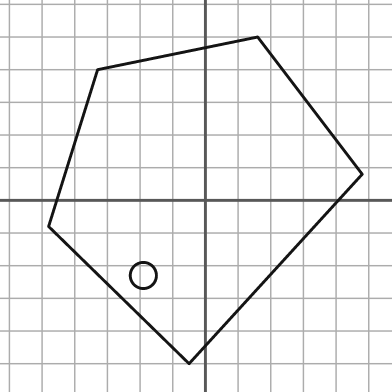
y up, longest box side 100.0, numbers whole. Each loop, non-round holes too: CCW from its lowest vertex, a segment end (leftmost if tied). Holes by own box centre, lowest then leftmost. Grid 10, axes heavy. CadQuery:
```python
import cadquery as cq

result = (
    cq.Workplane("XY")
    .moveTo(-5.0, -50.0)
    .lineTo(48.0, 8.0)
    .lineTo(16.0, 50.0)
    .lineTo(-33.0, 40.0)
    .lineTo(-48.0, -8.0)
    .close()
    .moveTo(-19.0, -23.0)
    .circle(4.0)
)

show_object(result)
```